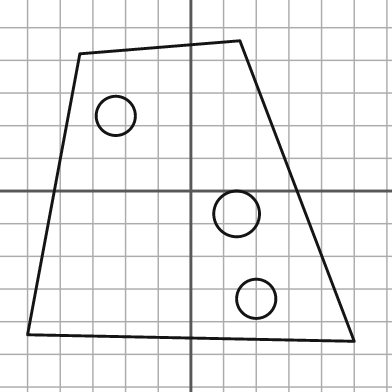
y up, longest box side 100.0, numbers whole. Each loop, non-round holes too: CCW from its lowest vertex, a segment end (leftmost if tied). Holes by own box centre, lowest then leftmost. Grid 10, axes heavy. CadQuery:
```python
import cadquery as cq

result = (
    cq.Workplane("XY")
    .moveTo(50.0, -46.0)
    .lineTo(15.0, 46.0)
    .lineTo(-34.0, 42.0)
    .lineTo(-50.0, -44.0)
    .close()
    .moveTo(20.0, -33.0)
    .circle(6.0)
    .moveTo(14.0, -7.0)
    .circle(7.0)
    .moveTo(-23.0, 23.0)
    .circle(6.0)
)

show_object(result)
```